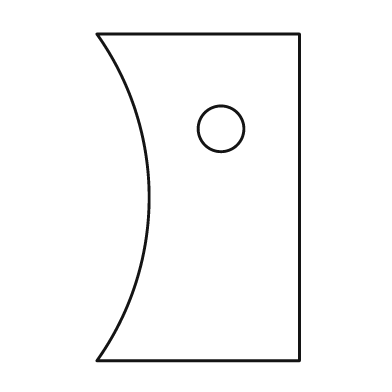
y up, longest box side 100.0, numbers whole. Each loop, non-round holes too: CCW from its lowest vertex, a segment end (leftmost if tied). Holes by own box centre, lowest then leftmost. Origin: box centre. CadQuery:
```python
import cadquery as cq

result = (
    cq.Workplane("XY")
    .moveTo(-31.0, -50.0)
    .lineTo(31.0, -50.0)
    .lineTo(31.0, 50.0)
    .lineTo(-31.0, 50.0)
    .threePointArc((-15.0, 0.0), (-31.0, -50.0))
    .close()
    .moveTo(7.0, 21.0)
    .circle(7.0)
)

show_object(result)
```